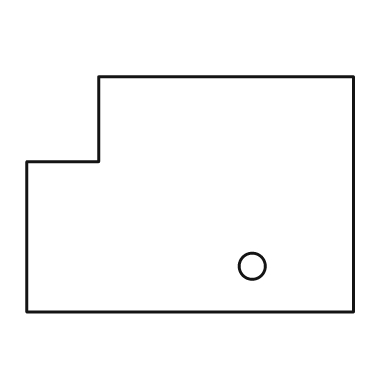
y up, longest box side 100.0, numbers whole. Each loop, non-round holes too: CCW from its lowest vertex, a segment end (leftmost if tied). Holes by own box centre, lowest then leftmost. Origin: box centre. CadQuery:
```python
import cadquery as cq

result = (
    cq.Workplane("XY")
    .moveTo(-50.0, -36.0)
    .lineTo(50.0, -36.0)
    .lineTo(50.0, 36.0)
    .lineTo(-28.0, 36.0)
    .lineTo(-28.0, 10.0)
    .lineTo(-50.0, 10.0)
    .close()
    .moveTo(19.0, -22.0)
    .circle(4.0)
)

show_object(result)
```